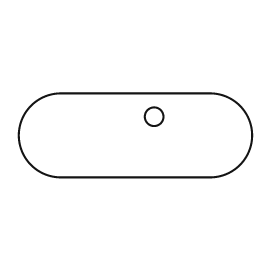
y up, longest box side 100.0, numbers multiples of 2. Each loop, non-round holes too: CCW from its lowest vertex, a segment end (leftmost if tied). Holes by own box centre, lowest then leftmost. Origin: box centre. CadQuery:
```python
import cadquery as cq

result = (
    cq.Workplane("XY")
    .moveTo(-32.0, -18.0)
    .lineTo(32.0, -18.0)
    .threePointArc((50.0, 0.0), (32.0, 18.0))
    .lineTo(-32.0, 18.0)
    .threePointArc((-50.0, 0.0), (-32.0, -18.0))
    .close()
    .moveTo(8.0, 8.0)
    .circle(4.0)
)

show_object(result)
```